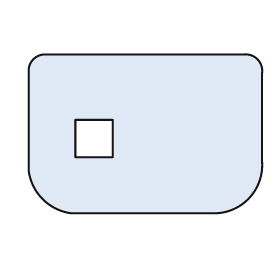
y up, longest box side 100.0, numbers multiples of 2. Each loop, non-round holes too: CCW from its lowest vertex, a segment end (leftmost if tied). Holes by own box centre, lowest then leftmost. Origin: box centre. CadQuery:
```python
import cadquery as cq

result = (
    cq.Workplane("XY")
    .moveTo(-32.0, -34.0)
    .lineTo(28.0, -34.0)
    .threePointArc((44.0, -28.0), (50.0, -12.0))
    .lineTo(50.0, 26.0)
    .threePointArc((48.0, 32.0), (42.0, 34.0))
    .lineTo(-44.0, 34.0)
    .threePointArc((-48.0, 32.0), (-50.0, 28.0))
    .lineTo(-50.0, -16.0)
    .threePointArc((-44.0, -28.0), (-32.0, -34.0))
    .close()
    .moveTo(-30.0, -10.0)
    .lineTo(-14.0, -10.0)
    .lineTo(-14.0, 6.0)
    .lineTo(-30.0, 6.0)
    .close()
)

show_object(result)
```